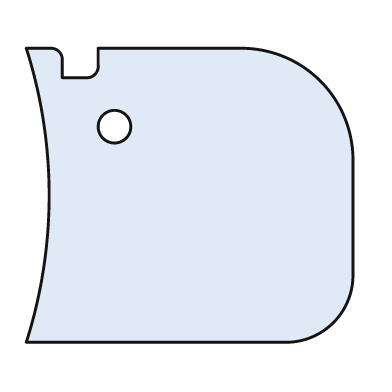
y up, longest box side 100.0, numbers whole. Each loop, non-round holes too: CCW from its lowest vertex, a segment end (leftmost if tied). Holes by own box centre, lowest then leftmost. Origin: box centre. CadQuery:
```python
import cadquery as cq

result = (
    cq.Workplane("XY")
    .moveTo(-50.0, -45.0)
    .lineTo(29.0, -45.0)
    .threePointArc((44.0, -39.0), (50.0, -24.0))
    .lineTo(50.0, 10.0)
    .threePointArc((40.0, 35.0), (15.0, 45.0))
    .lineTo(-28.0, 45.0)
    .lineTo(-28.0, 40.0)
    .threePointArc((-29.0, 37.0), (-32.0, 36.0))
    .lineTo(-39.0, 36.0)
    .lineTo(-39.0, 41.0)
    .threePointArc((-40.0, 44.0), (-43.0, 45.0))
    .lineTo(-50.0, 45.0)
    .threePointArc((-43.0, 0.0), (-50.0, -45.0))
    .close()
    .moveTo(-23.0, 21.0)
    .circle(5.0)
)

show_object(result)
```